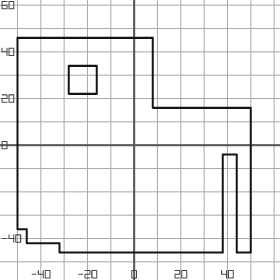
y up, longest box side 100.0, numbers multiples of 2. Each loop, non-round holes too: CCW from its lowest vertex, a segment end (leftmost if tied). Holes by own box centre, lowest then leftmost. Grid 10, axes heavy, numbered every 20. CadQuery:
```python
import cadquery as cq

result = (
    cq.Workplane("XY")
    .moveTo(-32.0, -46.0)
    .lineTo(38.0, -46.0)
    .lineTo(38.0, -4.0)
    .lineTo(44.0, -4.0)
    .lineTo(44.0, -46.0)
    .lineTo(50.0, -46.0)
    .lineTo(50.0, 16.0)
    .lineTo(8.0, 16.0)
    .lineTo(8.0, 46.0)
    .lineTo(-50.0, 46.0)
    .lineTo(-50.0, -36.0)
    .lineTo(-46.0, -36.0)
    .lineTo(-46.0, -42.0)
    .lineTo(-32.0, -42.0)
    .close()
    .moveTo(-28.0, 22.0)
    .lineTo(-16.0, 22.0)
    .lineTo(-16.0, 34.0)
    .lineTo(-28.0, 34.0)
    .close()
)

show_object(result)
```